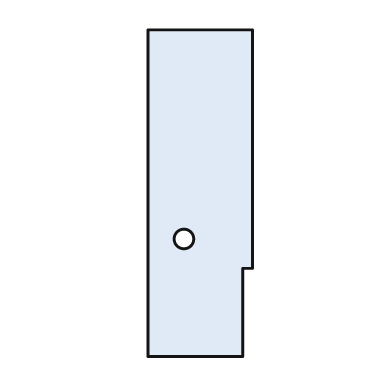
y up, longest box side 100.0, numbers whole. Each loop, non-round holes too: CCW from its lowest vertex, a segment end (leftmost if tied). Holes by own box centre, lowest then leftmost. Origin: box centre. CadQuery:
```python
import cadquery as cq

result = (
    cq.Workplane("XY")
    .moveTo(-16.0, -50.0)
    .lineTo(13.0, -50.0)
    .lineTo(13.0, -23.0)
    .lineTo(16.0, -23.0)
    .lineTo(16.0, 50.0)
    .lineTo(-16.0, 50.0)
    .close()
    .moveTo(-5.0, -14.0)
    .circle(3.0)
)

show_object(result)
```